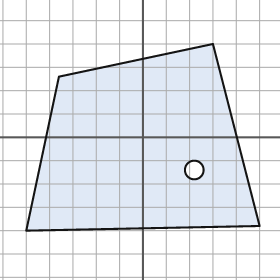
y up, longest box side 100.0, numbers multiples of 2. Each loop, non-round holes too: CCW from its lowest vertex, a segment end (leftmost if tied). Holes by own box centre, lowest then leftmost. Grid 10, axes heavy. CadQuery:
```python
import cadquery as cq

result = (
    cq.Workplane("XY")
    .moveTo(-50.0, -40.0)
    .lineTo(50.0, -38.0)
    .lineTo(30.0, 40.0)
    .lineTo(-36.0, 26.0)
    .close()
    .moveTo(22.0, -14.0)
    .circle(4.0)
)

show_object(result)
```